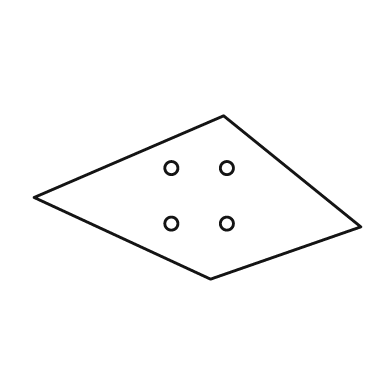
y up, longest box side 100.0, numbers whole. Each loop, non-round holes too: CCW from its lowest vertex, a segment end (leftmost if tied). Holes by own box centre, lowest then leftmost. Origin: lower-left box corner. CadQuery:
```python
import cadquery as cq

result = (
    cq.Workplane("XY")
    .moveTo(54.0, 0.0)
    .lineTo(100.0, 16.0)
    .lineTo(58.0, 50.0)
    .lineTo(0.0, 25.0)
    .close()
    .moveTo(42.0, 17.0)
    .circle(2.0)
    .moveTo(59.0, 17.0)
    .circle(2.0)
    .moveTo(42.0, 34.0)
    .circle(2.0)
    .moveTo(59.0, 34.0)
    .circle(2.0)
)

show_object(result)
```